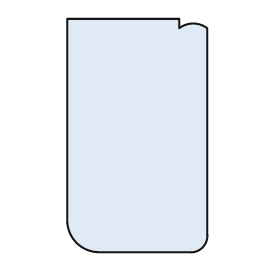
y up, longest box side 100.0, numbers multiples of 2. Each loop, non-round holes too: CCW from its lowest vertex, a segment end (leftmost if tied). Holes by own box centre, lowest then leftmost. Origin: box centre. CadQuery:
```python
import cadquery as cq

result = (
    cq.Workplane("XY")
    .moveTo(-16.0, -50.0)
    .lineTo(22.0, -50.0)
    .threePointArc((28.0, -48.0), (30.0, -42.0))
    .lineTo(30.0, 46.0)
    .threePointArc((24.0, 48.0), (18.0, 46.0))
    .lineTo(18.0, 50.0)
    .lineTo(-30.0, 50.0)
    .lineTo(-30.0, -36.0)
    .threePointArc((-26.0, -46.0), (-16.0, -50.0))
    .close()
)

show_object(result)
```